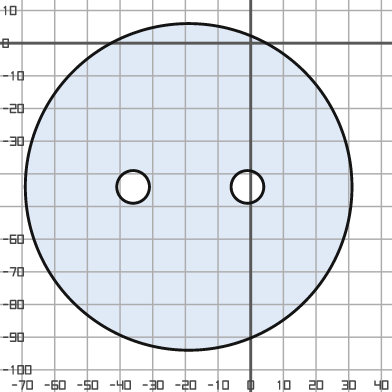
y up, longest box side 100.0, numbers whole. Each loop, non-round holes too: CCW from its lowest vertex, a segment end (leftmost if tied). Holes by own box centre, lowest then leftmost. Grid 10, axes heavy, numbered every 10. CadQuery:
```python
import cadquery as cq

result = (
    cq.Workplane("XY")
    .moveTo(-19.0, -44.0)
    .circle(50.0)
    .moveTo(-36.0, -44.0)
    .circle(5.0)
    .moveTo(-1.0, -44.0)
    .circle(5.0)
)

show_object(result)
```